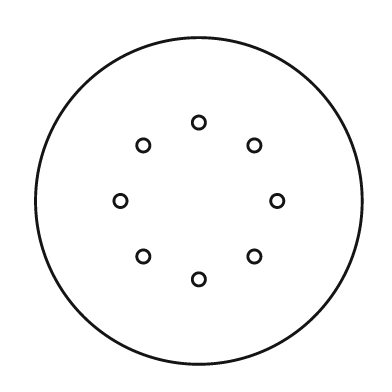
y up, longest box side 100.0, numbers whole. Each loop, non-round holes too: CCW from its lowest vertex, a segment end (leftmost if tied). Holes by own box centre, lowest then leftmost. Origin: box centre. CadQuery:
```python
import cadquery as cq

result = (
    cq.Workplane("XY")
    .moveTo(0.0, 0.0)
    .circle(50.0)
    .moveTo(0.0, -24.0)
    .circle(2.0)
    .moveTo(-17.0, -17.0)
    .circle(2.0)
    .moveTo(17.0, -17.0)
    .circle(2.0)
    .moveTo(-24.0, 0.0)
    .circle(2.0)
    .moveTo(24.0, 0.0)
    .circle(2.0)
    .moveTo(-17.0, 17.0)
    .circle(2.0)
    .moveTo(17.0, 17.0)
    .circle(2.0)
    .moveTo(0.0, 24.0)
    .circle(2.0)
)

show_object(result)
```